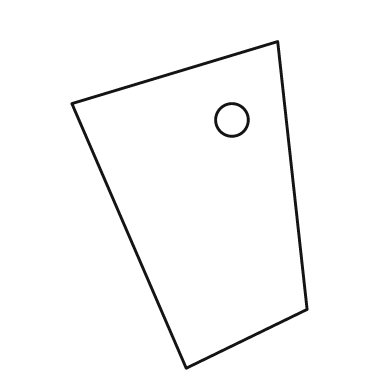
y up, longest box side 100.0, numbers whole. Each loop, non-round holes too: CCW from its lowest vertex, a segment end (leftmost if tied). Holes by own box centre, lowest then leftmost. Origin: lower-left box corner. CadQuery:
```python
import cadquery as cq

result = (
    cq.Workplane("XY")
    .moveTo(35.0, 0.0)
    .lineTo(72.0, 18.0)
    .lineTo(63.0, 100.0)
    .lineTo(0.0, 81.0)
    .close()
    .moveTo(49.0, 76.0)
    .circle(5.0)
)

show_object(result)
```